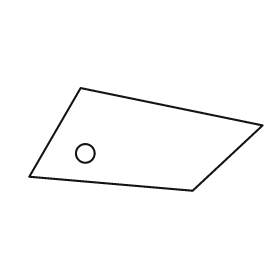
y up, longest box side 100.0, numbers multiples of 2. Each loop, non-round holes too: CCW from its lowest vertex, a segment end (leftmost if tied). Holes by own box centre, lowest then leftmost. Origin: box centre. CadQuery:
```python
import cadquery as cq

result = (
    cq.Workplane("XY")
    .moveTo(20.0, -22.0)
    .lineTo(50.0, 6.0)
    .lineTo(-28.0, 22.0)
    .lineTo(-50.0, -16.0)
    .close()
    .moveTo(-26.0, -6.0)
    .circle(4.0)
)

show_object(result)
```